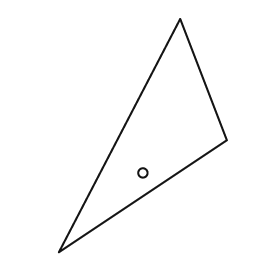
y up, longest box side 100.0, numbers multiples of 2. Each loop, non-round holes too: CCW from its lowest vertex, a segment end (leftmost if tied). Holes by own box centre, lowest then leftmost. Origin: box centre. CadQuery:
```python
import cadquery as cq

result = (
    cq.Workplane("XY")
    .moveTo(-36.0, -50.0)
    .lineTo(36.0, -2.0)
    .lineTo(16.0, 50.0)
    .close()
    .moveTo(0.0, -16.0)
    .circle(2.0)
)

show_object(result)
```